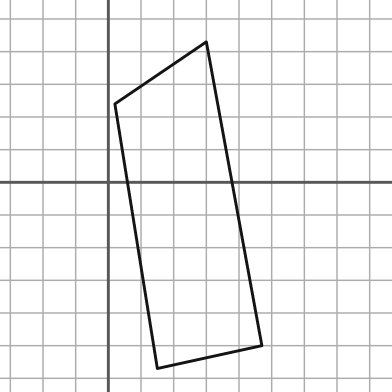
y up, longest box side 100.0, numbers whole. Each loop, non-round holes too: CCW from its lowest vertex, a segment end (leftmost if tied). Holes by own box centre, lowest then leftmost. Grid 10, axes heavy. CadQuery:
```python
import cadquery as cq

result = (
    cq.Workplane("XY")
    .moveTo(15.0, -57.0)
    .lineTo(47.0, -50.0)
    .lineTo(30.0, 43.0)
    .lineTo(2.0, 24.0)
    .close()
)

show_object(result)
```